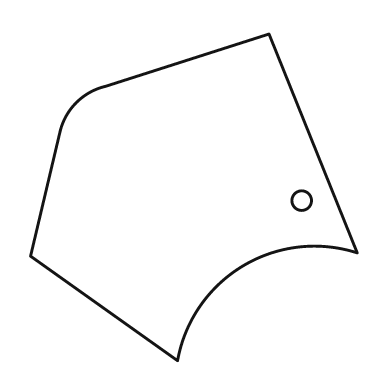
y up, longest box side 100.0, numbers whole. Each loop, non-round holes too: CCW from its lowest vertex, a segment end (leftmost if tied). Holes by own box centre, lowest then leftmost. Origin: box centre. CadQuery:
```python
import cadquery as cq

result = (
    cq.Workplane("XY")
    .moveTo(-5.0, -50.0)
    .threePointArc((15.0, -21.0), (50.0, -17.0))
    .lineTo(23.0, 50.0)
    .lineTo(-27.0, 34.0)
    .threePointArc((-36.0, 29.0), (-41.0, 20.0))
    .lineTo(-50.0, -18.0)
    .close()
    .moveTo(33.0, -1.0)
    .circle(3.0)
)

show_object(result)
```